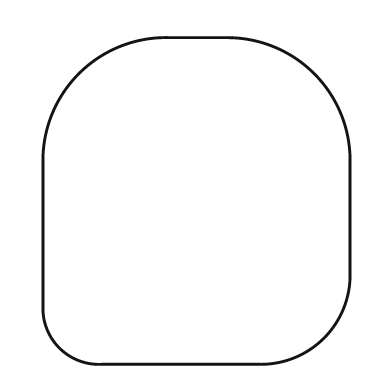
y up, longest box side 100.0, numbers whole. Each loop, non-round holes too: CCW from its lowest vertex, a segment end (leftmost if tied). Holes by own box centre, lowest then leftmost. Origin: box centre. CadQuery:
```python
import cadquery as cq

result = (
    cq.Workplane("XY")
    .moveTo(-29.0, -50.0)
    .lineTo(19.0, -50.0)
    .threePointArc((39.0, -42.0), (47.0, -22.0))
    .lineTo(47.0, 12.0)
    .threePointArc((36.0, 39.0), (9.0, 50.0))
    .lineTo(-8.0, 50.0)
    .threePointArc((-36.0, 39.0), (-47.0, 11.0))
    .lineTo(-47.0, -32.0)
    .threePointArc((-42.0, -45.0), (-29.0, -50.0))
    .close()
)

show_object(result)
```